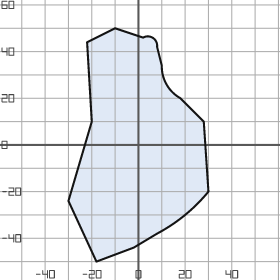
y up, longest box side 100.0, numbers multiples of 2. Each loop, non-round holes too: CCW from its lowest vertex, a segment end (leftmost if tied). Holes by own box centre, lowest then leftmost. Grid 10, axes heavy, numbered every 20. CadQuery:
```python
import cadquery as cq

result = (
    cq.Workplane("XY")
    .moveTo(-18.0, -50.0)
    .lineTo(-2.0, -44.0)
    .lineTo(8.0, -38.0)
    .threePointArc((20.0, -30.0), (30.0, -20.0))
    .lineTo(28.0, 10.0)
    .lineTo(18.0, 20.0)
    .threePointArc((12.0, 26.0), (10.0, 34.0))
    .lineTo(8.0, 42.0)
    .threePointArc((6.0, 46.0), (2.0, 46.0))
    .lineTo(-10.0, 50.0)
    .lineTo(-22.0, 44.0)
    .lineTo(-20.0, 10.0)
    .lineTo(-30.0, -24.0)
    .close()
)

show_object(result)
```